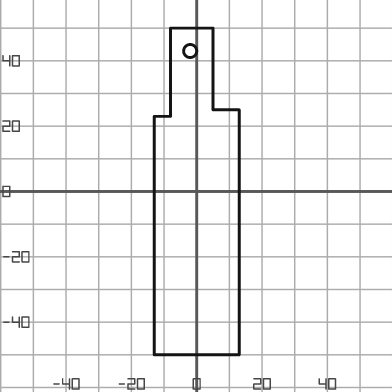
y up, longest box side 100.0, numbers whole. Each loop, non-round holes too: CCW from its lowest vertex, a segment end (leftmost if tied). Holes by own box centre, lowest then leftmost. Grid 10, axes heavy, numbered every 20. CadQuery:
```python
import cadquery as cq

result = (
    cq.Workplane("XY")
    .moveTo(-13.0, -50.0)
    .lineTo(13.0, -50.0)
    .lineTo(13.0, 25.0)
    .lineTo(5.0, 25.0)
    .lineTo(5.0, 50.0)
    .lineTo(-8.0, 50.0)
    .lineTo(-8.0, 23.0)
    .lineTo(-13.0, 23.0)
    .close()
    .moveTo(-2.0, 43.0)
    .circle(2.0)
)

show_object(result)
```